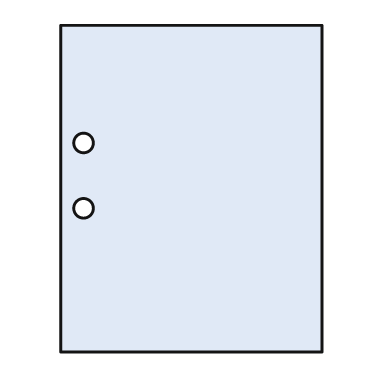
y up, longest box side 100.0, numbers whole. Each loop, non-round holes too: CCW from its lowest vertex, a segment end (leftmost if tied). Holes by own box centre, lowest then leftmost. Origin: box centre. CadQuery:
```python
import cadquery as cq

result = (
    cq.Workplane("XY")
    .moveTo(-40.0, -50.0)
    .lineTo(40.0, -50.0)
    .lineTo(40.0, 50.0)
    .lineTo(-40.0, 50.0)
    .close()
    .moveTo(-33.0, -6.0)
    .circle(3.0)
    .moveTo(-33.0, 14.0)
    .circle(3.0)
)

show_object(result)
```